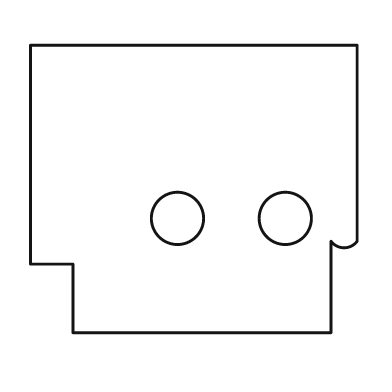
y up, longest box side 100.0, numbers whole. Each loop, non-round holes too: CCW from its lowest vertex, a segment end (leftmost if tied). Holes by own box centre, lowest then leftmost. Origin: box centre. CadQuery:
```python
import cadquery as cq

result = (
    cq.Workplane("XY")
    .moveTo(-37.0, -44.0)
    .lineTo(42.0, -44.0)
    .lineTo(42.0, -16.0)
    .threePointArc((46.0, -18.0), (50.0, -16.0))
    .lineTo(50.0, 44.0)
    .lineTo(-50.0, 44.0)
    .lineTo(-50.0, -23.0)
    .lineTo(-37.0, -23.0)
    .close()
    .moveTo(-5.0, -9.0)
    .circle(8.0)
    .moveTo(28.0, -9.0)
    .circle(8.0)
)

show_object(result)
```